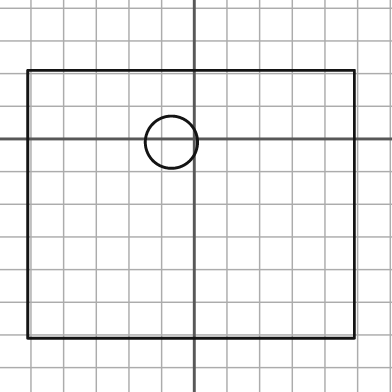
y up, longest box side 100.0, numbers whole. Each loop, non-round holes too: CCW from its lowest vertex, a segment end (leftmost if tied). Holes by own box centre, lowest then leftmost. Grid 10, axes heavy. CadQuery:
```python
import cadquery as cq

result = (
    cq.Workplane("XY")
    .moveTo(-51.0, -61.0)
    .lineTo(49.0, -61.0)
    .lineTo(49.0, 21.0)
    .lineTo(-51.0, 21.0)
    .close()
    .moveTo(-7.0, -1.0)
    .circle(8.0)
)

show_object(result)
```